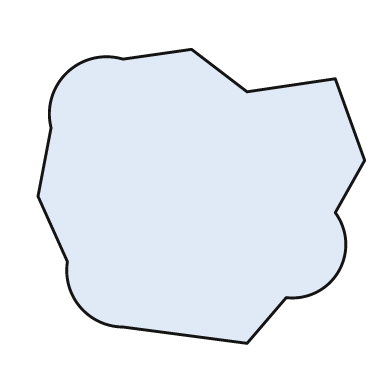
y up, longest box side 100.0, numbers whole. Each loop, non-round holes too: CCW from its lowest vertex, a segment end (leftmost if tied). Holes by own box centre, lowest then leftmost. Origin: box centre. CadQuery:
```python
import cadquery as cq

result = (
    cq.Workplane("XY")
    .moveTo(14.0, -45.0)
    .lineTo(26.0, -31.0)
    .threePointArc((42.0, -23.0), (41.0, -5.0))
    .lineTo(50.0, 11.0)
    .lineTo(41.0, 36.0)
    .lineTo(14.0, 32.0)
    .lineTo(-3.0, 45.0)
    .lineTo(-24.0, 42.0)
    .threePointArc((-41.0, 38.0), (-46.0, 21.0))
    .lineTo(-50.0, 0.0)
    .lineTo(-41.0, -20.0)
    .threePointArc((-37.0, -34.0), (-24.0, -40.0))
    .close()
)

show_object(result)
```